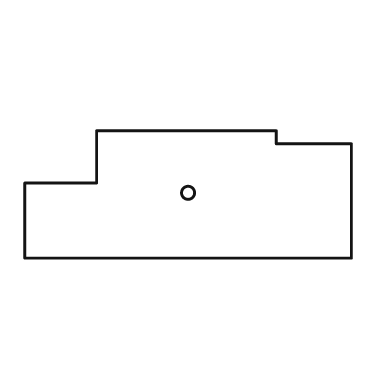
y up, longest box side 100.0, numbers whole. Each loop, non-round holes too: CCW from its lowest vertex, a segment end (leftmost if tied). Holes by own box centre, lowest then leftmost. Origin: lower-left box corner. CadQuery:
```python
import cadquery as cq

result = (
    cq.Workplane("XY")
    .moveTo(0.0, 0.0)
    .lineTo(100.0, 0.0)
    .lineTo(100.0, 35.0)
    .lineTo(77.0, 35.0)
    .lineTo(77.0, 39.0)
    .lineTo(22.0, 39.0)
    .lineTo(22.0, 23.0)
    .lineTo(0.0, 23.0)
    .close()
    .moveTo(50.0, 20.0)
    .circle(2.0)
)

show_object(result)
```